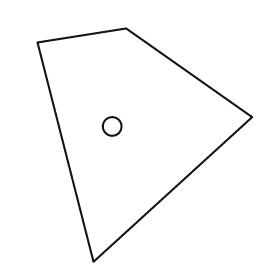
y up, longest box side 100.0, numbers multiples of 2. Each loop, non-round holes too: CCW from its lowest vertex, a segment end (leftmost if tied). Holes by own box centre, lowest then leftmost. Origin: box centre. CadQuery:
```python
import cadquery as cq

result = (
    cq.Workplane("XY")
    .moveTo(-22.0, -50.0)
    .lineTo(46.0, 12.0)
    .lineTo(-8.0, 50.0)
    .lineTo(-46.0, 44.0)
    .close()
    .moveTo(-14.0, 8.0)
    .circle(4.0)
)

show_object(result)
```